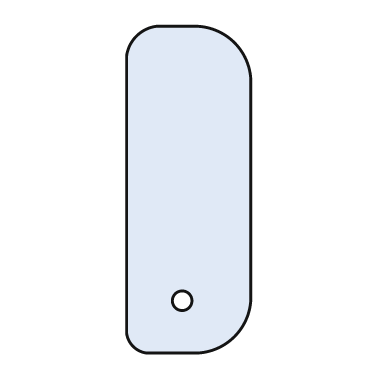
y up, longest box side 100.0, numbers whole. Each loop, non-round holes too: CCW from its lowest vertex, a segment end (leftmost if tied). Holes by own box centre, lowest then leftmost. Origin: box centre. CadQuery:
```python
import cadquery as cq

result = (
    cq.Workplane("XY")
    .moveTo(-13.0, -50.0)
    .lineTo(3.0, -50.0)
    .threePointArc((14.0, -45.0), (19.0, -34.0))
    .lineTo(19.0, 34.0)
    .threePointArc((14.0, 45.0), (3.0, 50.0))
    .lineTo(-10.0, 50.0)
    .threePointArc((-16.0, 47.0), (-19.0, 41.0))
    .lineTo(-19.0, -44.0)
    .threePointArc((-17.0, -48.0), (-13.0, -50.0))
    .close()
    .moveTo(-2.0, -34.0)
    .circle(3.0)
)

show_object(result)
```